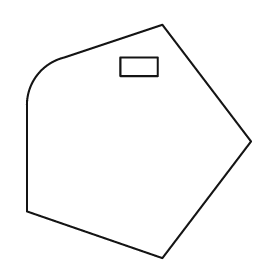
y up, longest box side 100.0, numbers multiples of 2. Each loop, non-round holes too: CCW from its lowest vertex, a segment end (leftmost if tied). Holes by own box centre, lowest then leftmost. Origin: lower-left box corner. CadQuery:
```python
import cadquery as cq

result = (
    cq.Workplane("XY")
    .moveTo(58.0, 0.0)
    .lineTo(96.0, 50.0)
    .lineTo(58.0, 100.0)
    .lineTo(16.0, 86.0)
    .threePointArc((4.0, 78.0), (0.0, 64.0))
    .lineTo(0.0, 20.0)
    .close()
    .moveTo(40.0, 78.0)
    .lineTo(56.0, 78.0)
    .lineTo(56.0, 86.0)
    .lineTo(40.0, 86.0)
    .close()
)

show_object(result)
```